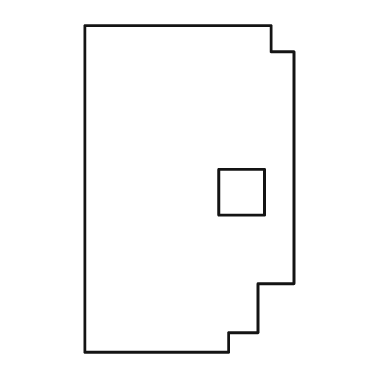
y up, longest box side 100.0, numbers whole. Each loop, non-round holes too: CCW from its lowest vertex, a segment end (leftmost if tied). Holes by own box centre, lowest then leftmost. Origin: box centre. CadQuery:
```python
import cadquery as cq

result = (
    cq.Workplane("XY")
    .moveTo(-32.0, -50.0)
    .lineTo(12.0, -50.0)
    .lineTo(12.0, -44.0)
    .lineTo(21.0, -44.0)
    .lineTo(21.0, -29.0)
    .lineTo(32.0, -29.0)
    .lineTo(32.0, 42.0)
    .lineTo(25.0, 42.0)
    .lineTo(25.0, 50.0)
    .lineTo(-32.0, 50.0)
    .close()
    .moveTo(9.0, -8.0)
    .lineTo(23.0, -8.0)
    .lineTo(23.0, 6.0)
    .lineTo(9.0, 6.0)
    .close()
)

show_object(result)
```